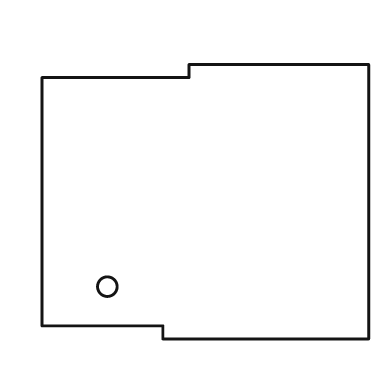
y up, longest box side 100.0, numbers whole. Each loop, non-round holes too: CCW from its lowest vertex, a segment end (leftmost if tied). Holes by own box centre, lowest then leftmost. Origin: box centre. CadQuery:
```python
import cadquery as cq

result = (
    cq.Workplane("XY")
    .moveTo(-13.0, -42.0)
    .lineTo(50.0, -42.0)
    .lineTo(50.0, 42.0)
    .lineTo(-5.0, 42.0)
    .lineTo(-5.0, 38.0)
    .lineTo(-50.0, 38.0)
    .lineTo(-50.0, -38.0)
    .lineTo(-13.0, -38.0)
    .close()
    .moveTo(-30.0, -26.0)
    .circle(3.0)
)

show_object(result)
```